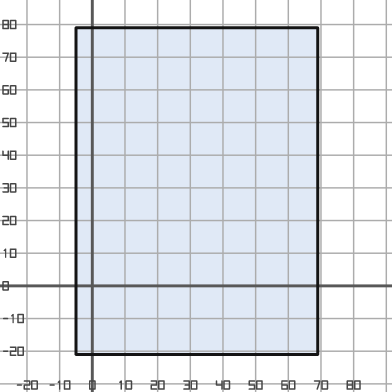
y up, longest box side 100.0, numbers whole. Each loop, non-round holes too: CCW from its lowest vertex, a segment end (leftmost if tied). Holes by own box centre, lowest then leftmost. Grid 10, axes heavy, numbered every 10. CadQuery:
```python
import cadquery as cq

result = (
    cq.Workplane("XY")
    .moveTo(-5.0, -21.0)
    .lineTo(69.0, -21.0)
    .lineTo(69.0, 79.0)
    .lineTo(-5.0, 79.0)
    .close()
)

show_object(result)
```